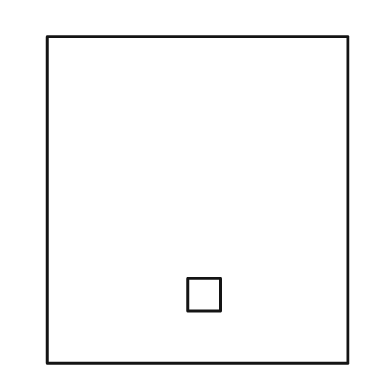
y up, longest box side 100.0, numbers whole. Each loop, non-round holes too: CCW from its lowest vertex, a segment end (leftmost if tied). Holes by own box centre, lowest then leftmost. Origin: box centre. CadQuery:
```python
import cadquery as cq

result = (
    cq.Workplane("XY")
    .moveTo(-46.0, -50.0)
    .lineTo(46.0, -50.0)
    .lineTo(46.0, 50.0)
    .lineTo(-46.0, 50.0)
    .close()
    .moveTo(-3.0, -34.0)
    .lineTo(7.0, -34.0)
    .lineTo(7.0, -24.0)
    .lineTo(-3.0, -24.0)
    .close()
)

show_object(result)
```